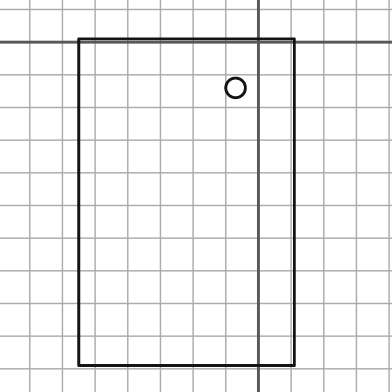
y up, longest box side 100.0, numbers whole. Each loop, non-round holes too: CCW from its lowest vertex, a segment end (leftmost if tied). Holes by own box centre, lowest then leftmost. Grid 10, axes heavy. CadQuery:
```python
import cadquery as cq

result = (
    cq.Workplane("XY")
    .moveTo(-55.0, -99.0)
    .lineTo(11.0, -99.0)
    .lineTo(11.0, 1.0)
    .lineTo(-55.0, 1.0)
    .close()
    .moveTo(-7.0, -14.0)
    .circle(3.0)
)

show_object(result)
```